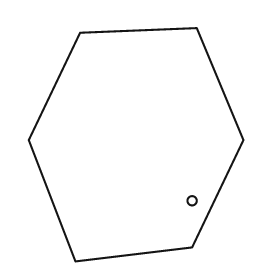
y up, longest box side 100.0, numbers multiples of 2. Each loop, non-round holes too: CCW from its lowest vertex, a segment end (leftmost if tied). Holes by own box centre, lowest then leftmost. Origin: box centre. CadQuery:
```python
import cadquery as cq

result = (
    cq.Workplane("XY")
    .moveTo(-26.0, -50.0)
    .lineTo(24.0, -44.0)
    .lineTo(46.0, 2.0)
    .lineTo(26.0, 50.0)
    .lineTo(-24.0, 48.0)
    .lineTo(-46.0, 2.0)
    .close()
    .moveTo(24.0, -24.0)
    .circle(2.0)
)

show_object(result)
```